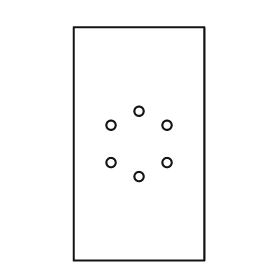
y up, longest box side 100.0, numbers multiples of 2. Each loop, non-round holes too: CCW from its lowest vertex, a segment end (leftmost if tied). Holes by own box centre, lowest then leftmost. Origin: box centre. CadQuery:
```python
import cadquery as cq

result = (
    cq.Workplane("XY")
    .moveTo(-28.0, -50.0)
    .lineTo(28.0, -50.0)
    .lineTo(28.0, 50.0)
    .lineTo(-28.0, 50.0)
    .close()
    .moveTo(0.0, -14.0)
    .circle(2.0)
    .moveTo(-12.0, -8.0)
    .circle(2.0)
    .moveTo(12.0, -8.0)
    .circle(2.0)
    .moveTo(-12.0, 8.0)
    .circle(2.0)
    .moveTo(12.0, 8.0)
    .circle(2.0)
    .moveTo(0.0, 14.0)
    .circle(2.0)
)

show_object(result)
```